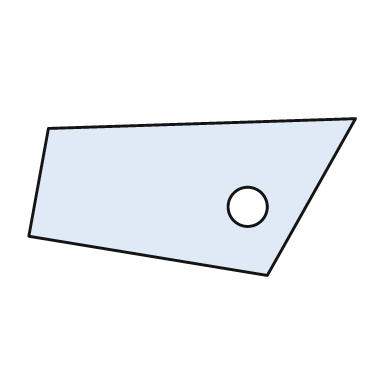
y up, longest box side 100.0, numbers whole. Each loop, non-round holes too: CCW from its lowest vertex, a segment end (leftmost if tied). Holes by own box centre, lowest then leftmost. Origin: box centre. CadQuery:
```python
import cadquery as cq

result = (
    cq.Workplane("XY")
    .moveTo(23.0, -24.0)
    .lineTo(50.0, 24.0)
    .lineTo(-44.0, 21.0)
    .lineTo(-50.0, -12.0)
    .close()
    .moveTo(17.0, -3.0)
    .circle(6.0)
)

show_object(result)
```